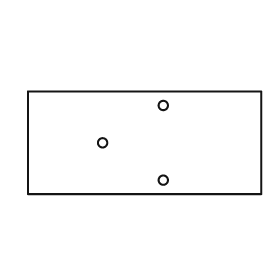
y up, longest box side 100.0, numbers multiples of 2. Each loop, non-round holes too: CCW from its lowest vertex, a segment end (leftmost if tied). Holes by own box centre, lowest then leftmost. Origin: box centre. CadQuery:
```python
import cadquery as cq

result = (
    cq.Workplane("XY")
    .moveTo(-50.0, -22.0)
    .lineTo(50.0, -22.0)
    .lineTo(50.0, 22.0)
    .lineTo(-50.0, 22.0)
    .close()
    .moveTo(8.0, -16.0)
    .circle(2.0)
    .moveTo(-18.0, 0.0)
    .circle(2.0)
    .moveTo(8.0, 16.0)
    .circle(2.0)
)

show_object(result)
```